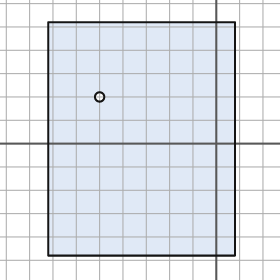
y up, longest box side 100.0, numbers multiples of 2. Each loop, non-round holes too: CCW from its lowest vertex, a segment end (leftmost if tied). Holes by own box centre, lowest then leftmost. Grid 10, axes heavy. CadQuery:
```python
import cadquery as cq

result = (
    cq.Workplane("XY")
    .moveTo(-72.0, -48.0)
    .lineTo(8.0, -48.0)
    .lineTo(8.0, 52.0)
    .lineTo(-72.0, 52.0)
    .close()
    .moveTo(-50.0, 20.0)
    .circle(2.0)
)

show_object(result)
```